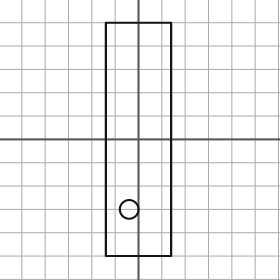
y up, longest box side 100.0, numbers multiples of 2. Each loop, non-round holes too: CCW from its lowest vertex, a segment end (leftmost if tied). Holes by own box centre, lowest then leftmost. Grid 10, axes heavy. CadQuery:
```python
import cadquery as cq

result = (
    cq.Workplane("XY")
    .moveTo(-14.0, -50.0)
    .lineTo(14.0, -50.0)
    .lineTo(14.0, 50.0)
    .lineTo(-14.0, 50.0)
    .close()
    .moveTo(-4.0, -30.0)
    .circle(4.0)
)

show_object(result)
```